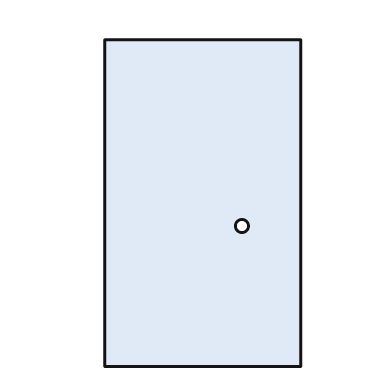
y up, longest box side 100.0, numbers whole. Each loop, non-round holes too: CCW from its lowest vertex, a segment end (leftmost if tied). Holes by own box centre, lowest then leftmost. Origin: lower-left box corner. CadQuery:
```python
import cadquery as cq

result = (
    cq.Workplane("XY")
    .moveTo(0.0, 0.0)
    .lineTo(60.0, 0.0)
    .lineTo(60.0, 100.0)
    .lineTo(0.0, 100.0)
    .close()
    .moveTo(42.0, 43.0)
    .circle(2.0)
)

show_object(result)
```